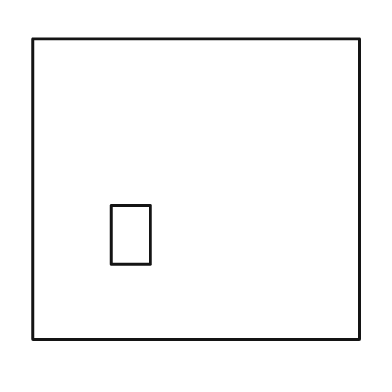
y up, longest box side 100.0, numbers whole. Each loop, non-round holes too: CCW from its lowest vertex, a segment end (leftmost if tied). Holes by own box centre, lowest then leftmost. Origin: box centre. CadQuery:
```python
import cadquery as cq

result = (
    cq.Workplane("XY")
    .moveTo(-50.0, -46.0)
    .lineTo(50.0, -46.0)
    .lineTo(50.0, 46.0)
    .lineTo(-50.0, 46.0)
    .close()
    .moveTo(-26.0, -23.0)
    .lineTo(-14.0, -23.0)
    .lineTo(-14.0, -5.0)
    .lineTo(-26.0, -5.0)
    .close()
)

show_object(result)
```